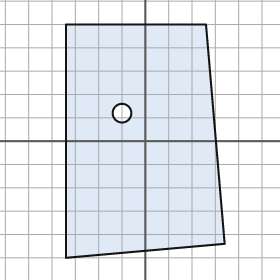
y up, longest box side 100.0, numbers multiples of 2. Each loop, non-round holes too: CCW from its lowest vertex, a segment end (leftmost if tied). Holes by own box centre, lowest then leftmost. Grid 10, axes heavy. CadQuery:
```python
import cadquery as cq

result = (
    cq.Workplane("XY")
    .moveTo(-34.0, -50.0)
    .lineTo(34.0, -44.0)
    .lineTo(26.0, 50.0)
    .lineTo(-34.0, 50.0)
    .close()
    .moveTo(-10.0, 12.0)
    .circle(4.0)
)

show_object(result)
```